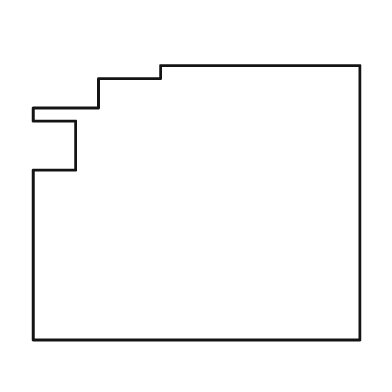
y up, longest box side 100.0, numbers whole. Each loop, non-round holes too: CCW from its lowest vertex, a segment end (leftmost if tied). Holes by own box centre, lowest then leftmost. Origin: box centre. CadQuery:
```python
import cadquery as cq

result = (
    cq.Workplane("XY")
    .moveTo(-50.0, -42.0)
    .lineTo(50.0, -42.0)
    .lineTo(50.0, 42.0)
    .lineTo(-11.0, 42.0)
    .lineTo(-11.0, 38.0)
    .lineTo(-30.0, 38.0)
    .lineTo(-30.0, 29.0)
    .lineTo(-50.0, 29.0)
    .lineTo(-50.0, 25.0)
    .lineTo(-37.0, 25.0)
    .lineTo(-37.0, 10.0)
    .lineTo(-50.0, 10.0)
    .close()
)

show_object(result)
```